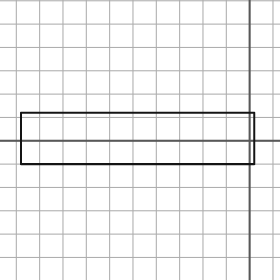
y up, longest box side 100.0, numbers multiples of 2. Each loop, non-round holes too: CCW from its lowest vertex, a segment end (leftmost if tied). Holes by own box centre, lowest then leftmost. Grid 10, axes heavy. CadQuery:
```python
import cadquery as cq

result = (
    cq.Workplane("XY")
    .moveTo(-98.0, -10.0)
    .lineTo(2.0, -10.0)
    .lineTo(2.0, 12.0)
    .lineTo(-98.0, 12.0)
    .close()
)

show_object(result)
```